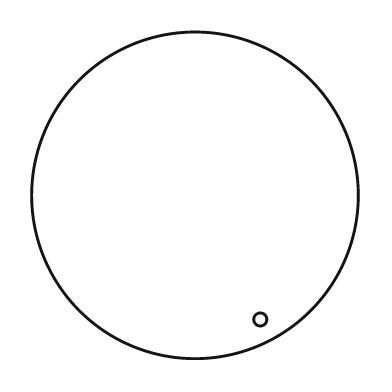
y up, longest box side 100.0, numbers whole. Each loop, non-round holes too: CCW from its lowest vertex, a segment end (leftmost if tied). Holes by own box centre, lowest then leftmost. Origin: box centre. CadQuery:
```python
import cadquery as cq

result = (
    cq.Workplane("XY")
    .moveTo(0.0, 0.0)
    .circle(50.0)
    .moveTo(20.0, -38.0)
    .circle(2.0)
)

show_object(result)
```